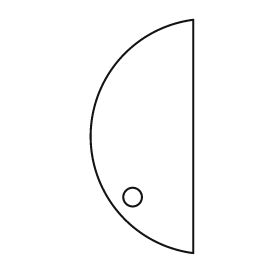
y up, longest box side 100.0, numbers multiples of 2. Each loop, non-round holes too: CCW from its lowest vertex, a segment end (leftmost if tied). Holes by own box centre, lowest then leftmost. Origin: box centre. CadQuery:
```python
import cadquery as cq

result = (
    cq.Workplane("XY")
    .moveTo(22.0, -50.0)
    .lineTo(22.0, 50.0)
    .threePointArc((-22.0, 0.0), (22.0, -50.0))
    .close()
    .moveTo(-4.0, -26.0)
    .circle(4.0)
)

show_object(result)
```